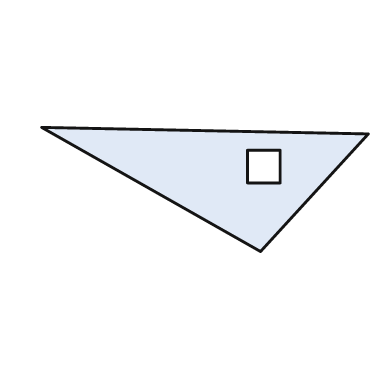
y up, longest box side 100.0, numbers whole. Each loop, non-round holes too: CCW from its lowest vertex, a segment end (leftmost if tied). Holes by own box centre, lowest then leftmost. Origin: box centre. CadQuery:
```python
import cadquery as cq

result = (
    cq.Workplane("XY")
    .moveTo(17.0, -19.0)
    .lineTo(50.0, 17.0)
    .lineTo(-50.0, 19.0)
    .close()
    .moveTo(13.0, 2.0)
    .lineTo(23.0, 2.0)
    .lineTo(23.0, 12.0)
    .lineTo(13.0, 12.0)
    .close()
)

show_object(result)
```